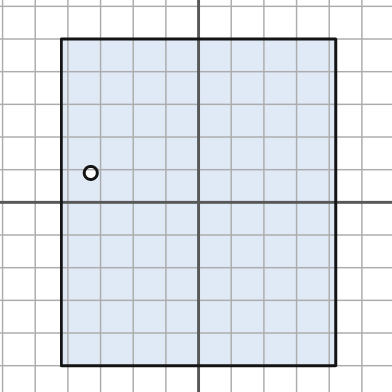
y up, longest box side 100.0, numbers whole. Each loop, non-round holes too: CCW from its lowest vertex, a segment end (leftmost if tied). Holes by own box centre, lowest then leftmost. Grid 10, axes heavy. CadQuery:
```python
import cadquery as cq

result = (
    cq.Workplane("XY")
    .moveTo(-42.0, -50.0)
    .lineTo(42.0, -50.0)
    .lineTo(42.0, 50.0)
    .lineTo(-42.0, 50.0)
    .close()
    .moveTo(-33.0, 9.0)
    .circle(2.0)
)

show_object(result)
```